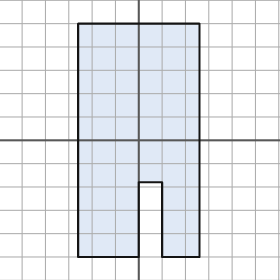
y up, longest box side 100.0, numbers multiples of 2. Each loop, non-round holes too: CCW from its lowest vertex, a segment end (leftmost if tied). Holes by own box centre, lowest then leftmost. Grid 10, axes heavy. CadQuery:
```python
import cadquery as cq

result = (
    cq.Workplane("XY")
    .moveTo(-26.0, -50.0)
    .lineTo(0.0, -50.0)
    .lineTo(0.0, -18.0)
    .lineTo(10.0, -18.0)
    .lineTo(10.0, -50.0)
    .lineTo(26.0, -50.0)
    .lineTo(26.0, 50.0)
    .lineTo(-26.0, 50.0)
    .close()
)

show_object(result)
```